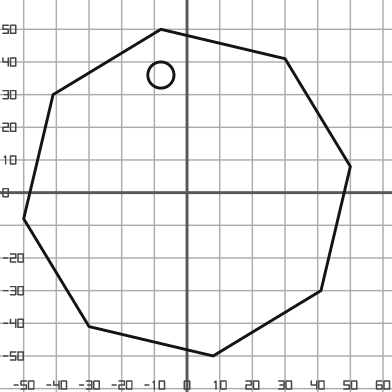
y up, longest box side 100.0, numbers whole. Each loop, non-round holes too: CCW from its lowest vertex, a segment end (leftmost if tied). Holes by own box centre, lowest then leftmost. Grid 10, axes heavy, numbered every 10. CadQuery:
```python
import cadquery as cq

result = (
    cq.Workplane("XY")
    .moveTo(8.0, -50.0)
    .lineTo(41.0, -30.0)
    .lineTo(50.0, 8.0)
    .lineTo(30.0, 41.0)
    .lineTo(-8.0, 50.0)
    .lineTo(-41.0, 30.0)
    .lineTo(-50.0, -8.0)
    .lineTo(-30.0, -41.0)
    .close()
    .moveTo(-8.0, 36.0)
    .circle(4.0)
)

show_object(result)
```